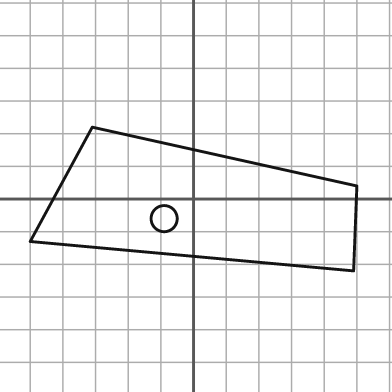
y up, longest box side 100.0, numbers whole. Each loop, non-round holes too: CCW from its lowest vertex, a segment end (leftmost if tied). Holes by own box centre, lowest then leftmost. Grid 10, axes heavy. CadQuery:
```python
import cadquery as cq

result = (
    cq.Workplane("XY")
    .moveTo(49.0, -22.0)
    .lineTo(50.0, 4.0)
    .lineTo(-31.0, 22.0)
    .lineTo(-50.0, -13.0)
    .close()
    .moveTo(-9.0, -6.0)
    .circle(4.0)
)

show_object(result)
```